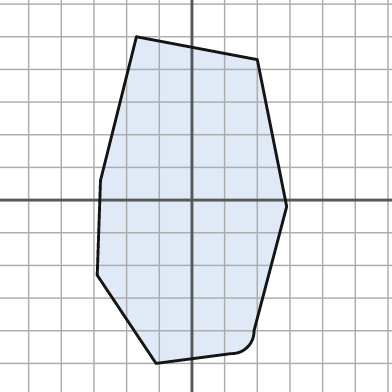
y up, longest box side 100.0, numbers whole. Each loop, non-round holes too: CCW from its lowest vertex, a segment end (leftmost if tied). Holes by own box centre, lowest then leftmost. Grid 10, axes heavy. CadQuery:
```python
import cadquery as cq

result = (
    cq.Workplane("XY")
    .moveTo(-11.0, -50.0)
    .lineTo(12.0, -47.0)
    .threePointArc((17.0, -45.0), (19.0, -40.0))
    .lineTo(29.0, -2.0)
    .lineTo(20.0, 43.0)
    .lineTo(-17.0, 50.0)
    .lineTo(-28.0, 6.0)
    .lineTo(-29.0, -23.0)
    .close()
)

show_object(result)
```